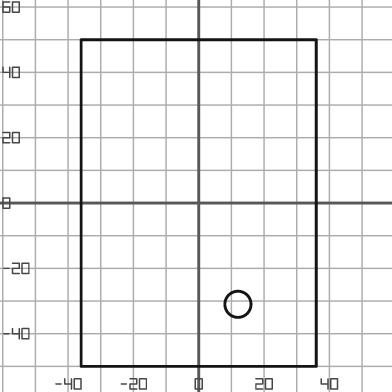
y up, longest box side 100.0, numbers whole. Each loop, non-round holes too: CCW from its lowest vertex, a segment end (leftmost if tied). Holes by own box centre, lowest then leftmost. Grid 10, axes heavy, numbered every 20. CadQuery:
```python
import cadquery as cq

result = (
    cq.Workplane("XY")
    .moveTo(-36.0, -50.0)
    .lineTo(36.0, -50.0)
    .lineTo(36.0, 50.0)
    .lineTo(-36.0, 50.0)
    .close()
    .moveTo(12.0, -31.0)
    .circle(4.0)
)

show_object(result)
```